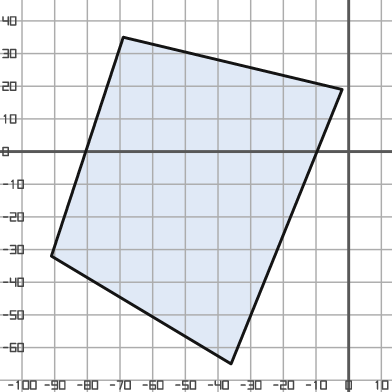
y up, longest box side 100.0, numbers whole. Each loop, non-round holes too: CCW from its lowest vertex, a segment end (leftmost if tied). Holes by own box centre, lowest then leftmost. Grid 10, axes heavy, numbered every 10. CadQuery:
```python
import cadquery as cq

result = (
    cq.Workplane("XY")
    .moveTo(-36.0, -65.0)
    .lineTo(-2.0, 19.0)
    .lineTo(-69.0, 35.0)
    .lineTo(-91.0, -32.0)
    .close()
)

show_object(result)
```